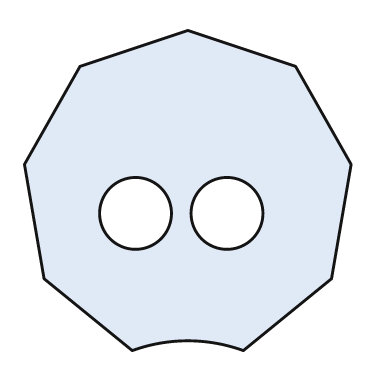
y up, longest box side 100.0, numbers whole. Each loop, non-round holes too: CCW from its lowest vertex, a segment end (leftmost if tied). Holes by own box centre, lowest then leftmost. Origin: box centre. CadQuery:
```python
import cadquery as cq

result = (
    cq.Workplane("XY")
    .moveTo(-17.0, -49.0)
    .threePointArc((0.0, -46.0), (17.0, -49.0))
    .lineTo(44.0, -27.0)
    .lineTo(50.0, 8.0)
    .lineTo(33.0, 38.0)
    .lineTo(0.0, 49.0)
    .lineTo(-33.0, 38.0)
    .lineTo(-50.0, 8.0)
    .lineTo(-44.0, -27.0)
    .close()
    .moveTo(-16.0, -7.0)
    .circle(11.0)
    .moveTo(12.0, -7.0)
    .circle(11.0)
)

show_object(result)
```